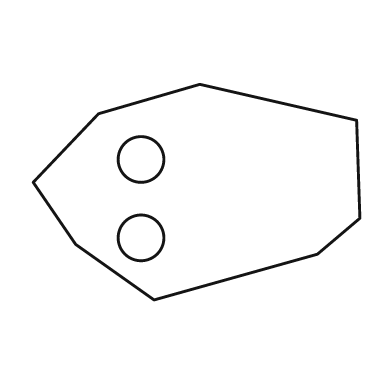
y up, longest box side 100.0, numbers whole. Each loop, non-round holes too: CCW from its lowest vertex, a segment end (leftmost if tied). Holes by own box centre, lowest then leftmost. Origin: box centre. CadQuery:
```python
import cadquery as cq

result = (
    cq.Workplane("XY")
    .moveTo(-13.0, -33.0)
    .lineTo(37.0, -19.0)
    .lineTo(50.0, -8.0)
    .lineTo(49.0, 22.0)
    .lineTo(1.0, 33.0)
    .lineTo(-30.0, 24.0)
    .lineTo(-50.0, 3.0)
    .lineTo(-37.0, -16.0)
    .close()
    .moveTo(-17.0, -14.0)
    .circle(7.0)
    .moveTo(-17.0, 10.0)
    .circle(7.0)
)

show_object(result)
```